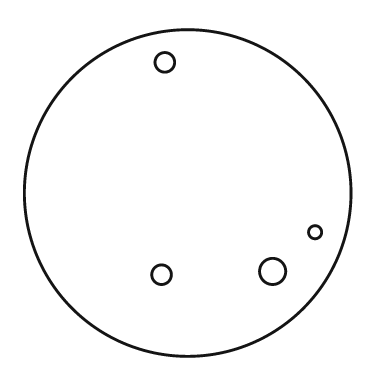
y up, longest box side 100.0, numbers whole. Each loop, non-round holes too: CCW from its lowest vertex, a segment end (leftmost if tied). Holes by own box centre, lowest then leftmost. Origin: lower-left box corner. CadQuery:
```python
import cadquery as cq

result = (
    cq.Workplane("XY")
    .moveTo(50.0, 50.0)
    .circle(50.0)
    .moveTo(42.0, 25.0)
    .circle(3.0)
    .moveTo(76.0, 26.0)
    .circle(4.0)
    .moveTo(89.0, 38.0)
    .circle(2.0)
    .moveTo(43.0, 90.0)
    .circle(3.0)
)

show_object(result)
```